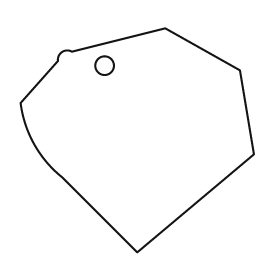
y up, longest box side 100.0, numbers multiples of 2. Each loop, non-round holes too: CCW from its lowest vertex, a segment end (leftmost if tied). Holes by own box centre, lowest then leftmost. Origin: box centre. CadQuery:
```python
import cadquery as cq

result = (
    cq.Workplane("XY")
    .moveTo(0.0, -48.0)
    .lineTo(50.0, -6.0)
    .lineTo(44.0, 30.0)
    .lineTo(12.0, 48.0)
    .lineTo(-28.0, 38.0)
    .threePointArc((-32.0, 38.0), (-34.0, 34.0))
    .lineTo(-50.0, 16.0)
    .threePointArc((-44.0, -2.0), (-32.0, -16.0))
    .close()
    .moveTo(-14.0, 32.0)
    .circle(4.0)
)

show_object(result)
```